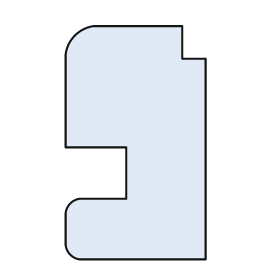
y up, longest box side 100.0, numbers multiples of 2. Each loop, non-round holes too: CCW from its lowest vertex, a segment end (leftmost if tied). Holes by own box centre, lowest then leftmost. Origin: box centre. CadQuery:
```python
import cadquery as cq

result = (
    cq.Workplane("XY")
    .moveTo(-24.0, -50.0)
    .lineTo(30.0, -50.0)
    .lineTo(30.0, 36.0)
    .lineTo(20.0, 36.0)
    .lineTo(20.0, 50.0)
    .lineTo(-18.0, 50.0)
    .threePointArc((-26.0, 46.0), (-30.0, 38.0))
    .lineTo(-30.0, -2.0)
    .lineTo(-4.0, -2.0)
    .lineTo(-4.0, -24.0)
    .lineTo(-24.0, -24.0)
    .threePointArc((-28.0, -26.0), (-30.0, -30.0))
    .lineTo(-30.0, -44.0)
    .threePointArc((-28.0, -48.0), (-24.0, -50.0))
    .close()
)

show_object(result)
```